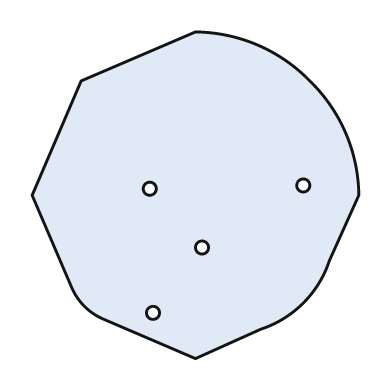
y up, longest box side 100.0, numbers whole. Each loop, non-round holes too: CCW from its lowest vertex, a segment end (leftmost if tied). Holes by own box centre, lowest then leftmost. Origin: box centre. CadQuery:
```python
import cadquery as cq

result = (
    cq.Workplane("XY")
    .moveTo(0.0, -50.0)
    .lineTo(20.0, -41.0)
    .threePointArc((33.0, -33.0), (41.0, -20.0))
    .lineTo(50.0, 0.0)
    .threePointArc((46.0, 19.0), (35.0, 35.0))
    .threePointArc((19.0, 46.0), (0.0, 50.0))
    .lineTo(-35.0, 35.0)
    .lineTo(-50.0, 0.0)
    .lineTo(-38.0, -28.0)
    .threePointArc((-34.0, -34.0), (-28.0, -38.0))
    .close()
    .moveTo(-13.0, -36.0)
    .circle(2.0)
    .moveTo(2.0, -16.0)
    .circle(2.0)
    .moveTo(-14.0, 2.0)
    .circle(2.0)
    .moveTo(33.0, 3.0)
    .circle(2.0)
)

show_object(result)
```